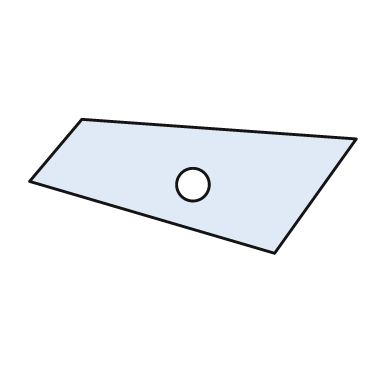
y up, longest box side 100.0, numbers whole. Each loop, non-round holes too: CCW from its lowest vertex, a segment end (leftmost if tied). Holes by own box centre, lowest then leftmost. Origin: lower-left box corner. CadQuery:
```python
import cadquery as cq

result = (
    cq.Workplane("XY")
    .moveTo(75.0, 0.0)
    .lineTo(100.0, 35.0)
    .lineTo(16.0, 41.0)
    .lineTo(0.0, 22.0)
    .close()
    .moveTo(50.0, 21.0)
    .circle(5.0)
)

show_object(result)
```